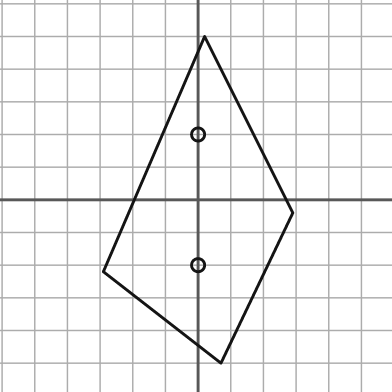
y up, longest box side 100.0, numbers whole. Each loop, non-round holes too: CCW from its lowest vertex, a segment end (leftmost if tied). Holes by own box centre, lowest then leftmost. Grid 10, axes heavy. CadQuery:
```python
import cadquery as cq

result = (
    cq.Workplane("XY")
    .moveTo(7.0, -50.0)
    .lineTo(29.0, -4.0)
    .lineTo(2.0, 50.0)
    .lineTo(-29.0, -22.0)
    .close()
    .moveTo(0.0, -20.0)
    .circle(2.0)
    .moveTo(0.0, 20.0)
    .circle(2.0)
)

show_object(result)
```